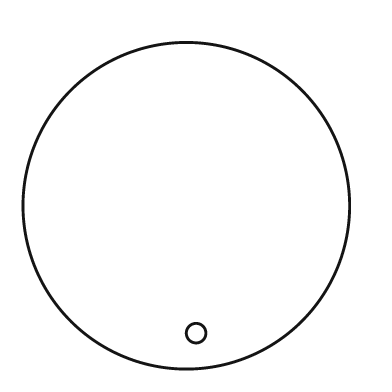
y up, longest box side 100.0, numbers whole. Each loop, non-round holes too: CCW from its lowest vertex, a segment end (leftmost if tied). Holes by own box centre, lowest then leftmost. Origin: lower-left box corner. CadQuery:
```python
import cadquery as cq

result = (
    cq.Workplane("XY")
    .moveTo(50.0, 50.0)
    .circle(50.0)
    .moveTo(53.0, 11.0)
    .circle(3.0)
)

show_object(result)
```